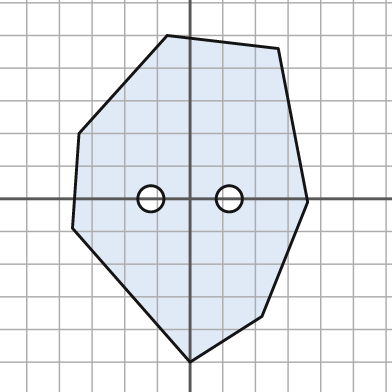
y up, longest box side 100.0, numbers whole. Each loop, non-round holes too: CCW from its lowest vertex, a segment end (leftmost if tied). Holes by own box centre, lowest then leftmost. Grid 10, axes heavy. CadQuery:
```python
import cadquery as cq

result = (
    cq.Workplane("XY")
    .moveTo(0.0, -50.0)
    .lineTo(22.0, -36.0)
    .lineTo(36.0, -1.0)
    .lineTo(27.0, 46.0)
    .lineTo(-7.0, 50.0)
    .lineTo(-34.0, 20.0)
    .lineTo(-36.0, -9.0)
    .close()
    .moveTo(-12.0, 0.0)
    .circle(4.0)
    .moveTo(12.0, 0.0)
    .circle(4.0)
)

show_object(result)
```